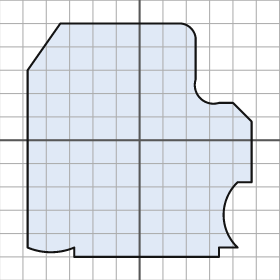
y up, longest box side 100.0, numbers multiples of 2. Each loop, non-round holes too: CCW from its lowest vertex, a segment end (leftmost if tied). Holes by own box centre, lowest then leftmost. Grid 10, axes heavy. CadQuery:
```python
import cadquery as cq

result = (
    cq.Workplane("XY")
    .moveTo(-28.0, -50.0)
    .lineTo(34.0, -50.0)
    .lineTo(34.0, -46.0)
    .lineTo(42.0, -46.0)
    .threePointArc((36.0, -32.0), (42.0, -18.0))
    .lineTo(48.0, -18.0)
    .lineTo(48.0, 8.0)
    .lineTo(40.0, 16.0)
    .lineTo(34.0, 16.0)
    .threePointArc((26.0, 18.0), (24.0, 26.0))
    .lineTo(24.0, 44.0)
    .threePointArc((22.0, 48.0), (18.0, 50.0))
    .lineTo(-34.0, 50.0)
    .lineTo(-48.0, 30.0)
    .lineTo(-48.0, -46.0)
    .threePointArc((-38.0, -48.0), (-28.0, -46.0))
    .close()
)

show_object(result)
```